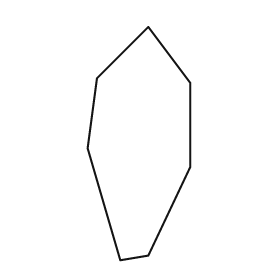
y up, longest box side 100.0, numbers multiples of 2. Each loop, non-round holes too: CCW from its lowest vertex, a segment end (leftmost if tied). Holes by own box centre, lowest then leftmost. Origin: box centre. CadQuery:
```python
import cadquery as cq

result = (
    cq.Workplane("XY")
    .moveTo(-8.0, -50.0)
    .lineTo(4.0, -48.0)
    .lineTo(22.0, -10.0)
    .lineTo(22.0, 26.0)
    .lineTo(4.0, 50.0)
    .lineTo(-18.0, 28.0)
    .lineTo(-22.0, -2.0)
    .close()
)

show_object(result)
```